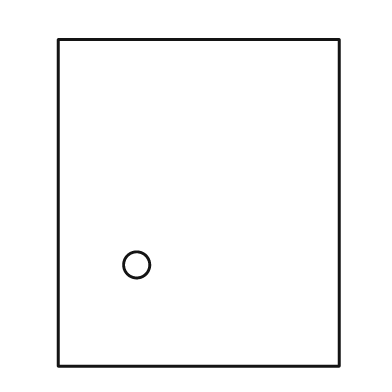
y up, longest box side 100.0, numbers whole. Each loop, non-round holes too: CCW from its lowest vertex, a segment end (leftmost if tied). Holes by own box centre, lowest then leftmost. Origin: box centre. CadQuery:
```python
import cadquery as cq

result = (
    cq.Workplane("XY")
    .moveTo(-43.0, -50.0)
    .lineTo(43.0, -50.0)
    .lineTo(43.0, 50.0)
    .lineTo(-43.0, 50.0)
    .close()
    .moveTo(-19.0, -19.0)
    .circle(4.0)
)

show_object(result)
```